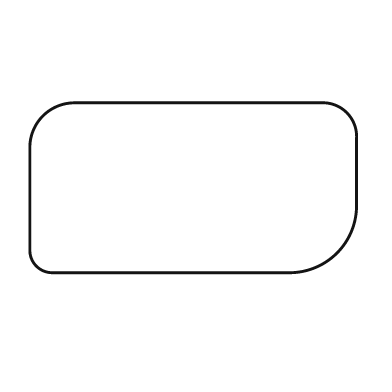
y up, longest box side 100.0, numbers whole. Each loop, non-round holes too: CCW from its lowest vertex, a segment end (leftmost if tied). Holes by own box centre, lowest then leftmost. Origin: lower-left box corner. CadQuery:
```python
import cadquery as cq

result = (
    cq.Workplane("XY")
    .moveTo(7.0, 0.0)
    .lineTo(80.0, 0.0)
    .threePointArc((94.0, 6.0), (100.0, 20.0))
    .lineTo(100.0, 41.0)
    .threePointArc((97.0, 49.0), (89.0, 52.0))
    .lineTo(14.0, 52.0)
    .threePointArc((4.0, 48.0), (0.0, 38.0))
    .lineTo(0.0, 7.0)
    .threePointArc((2.0, 2.0), (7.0, 0.0))
    .close()
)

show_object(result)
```